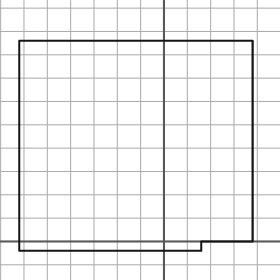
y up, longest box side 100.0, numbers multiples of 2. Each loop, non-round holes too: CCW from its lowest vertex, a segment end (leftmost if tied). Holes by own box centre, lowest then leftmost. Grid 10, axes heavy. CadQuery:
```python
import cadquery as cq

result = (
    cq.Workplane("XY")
    .moveTo(-62.0, -4.0)
    .lineTo(16.0, -4.0)
    .lineTo(16.0, 0.0)
    .lineTo(38.0, 0.0)
    .lineTo(38.0, 86.0)
    .lineTo(-62.0, 86.0)
    .close()
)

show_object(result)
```